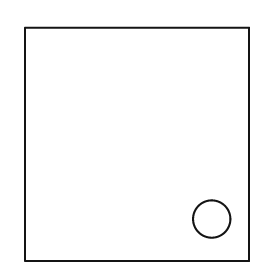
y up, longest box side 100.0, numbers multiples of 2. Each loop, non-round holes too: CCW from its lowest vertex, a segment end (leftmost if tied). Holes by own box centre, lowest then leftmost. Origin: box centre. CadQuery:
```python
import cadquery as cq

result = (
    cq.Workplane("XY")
    .moveTo(-48.0, -50.0)
    .lineTo(48.0, -50.0)
    .lineTo(48.0, 50.0)
    .lineTo(-48.0, 50.0)
    .close()
    .moveTo(32.0, -32.0)
    .circle(8.0)
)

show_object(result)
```